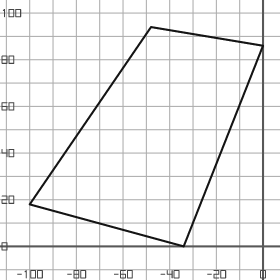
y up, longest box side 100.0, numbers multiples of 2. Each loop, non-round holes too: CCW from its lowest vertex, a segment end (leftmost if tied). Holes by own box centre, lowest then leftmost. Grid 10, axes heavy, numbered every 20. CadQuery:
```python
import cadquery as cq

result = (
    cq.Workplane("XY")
    .moveTo(-34.0, 0.0)
    .lineTo(0.0, 86.0)
    .lineTo(-48.0, 94.0)
    .lineTo(-100.0, 18.0)
    .close()
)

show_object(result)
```